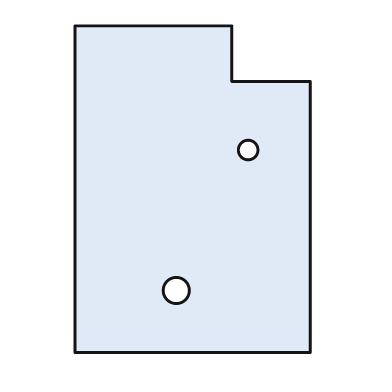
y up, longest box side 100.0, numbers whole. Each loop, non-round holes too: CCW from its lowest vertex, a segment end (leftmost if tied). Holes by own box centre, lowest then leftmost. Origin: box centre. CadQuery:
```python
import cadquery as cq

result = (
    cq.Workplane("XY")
    .moveTo(-36.0, -50.0)
    .lineTo(36.0, -50.0)
    .lineTo(36.0, 33.0)
    .lineTo(12.0, 33.0)
    .lineTo(12.0, 50.0)
    .lineTo(-36.0, 50.0)
    .close()
    .moveTo(-5.0, -31.0)
    .circle(4.0)
    .moveTo(17.0, 12.0)
    .circle(3.0)
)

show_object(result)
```